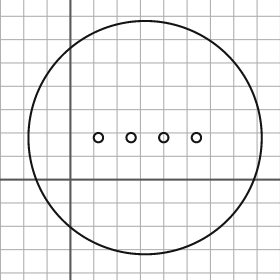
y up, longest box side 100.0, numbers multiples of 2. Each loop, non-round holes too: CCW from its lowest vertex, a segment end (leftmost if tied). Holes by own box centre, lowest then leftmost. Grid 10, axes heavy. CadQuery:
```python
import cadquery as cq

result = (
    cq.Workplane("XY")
    .moveTo(32.0, 18.0)
    .circle(50.0)
    .moveTo(12.0, 18.0)
    .circle(2.0)
    .moveTo(26.0, 18.0)
    .circle(2.0)
    .moveTo(40.0, 18.0)
    .circle(2.0)
    .moveTo(54.0, 18.0)
    .circle(2.0)
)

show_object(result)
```